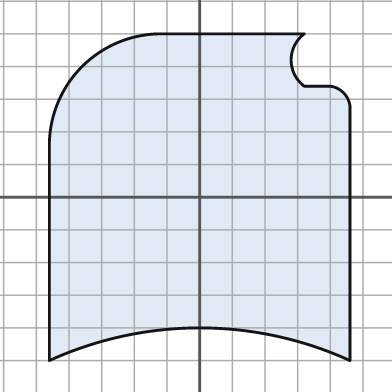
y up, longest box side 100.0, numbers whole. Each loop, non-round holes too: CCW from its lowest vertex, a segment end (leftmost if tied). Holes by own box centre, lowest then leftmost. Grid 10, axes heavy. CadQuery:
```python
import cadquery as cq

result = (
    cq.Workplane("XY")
    .moveTo(-46.0, -50.0)
    .threePointArc((0.0, -40.0), (46.0, -50.0))
    .lineTo(46.0, 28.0)
    .threePointArc((44.0, 32.0), (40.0, 34.0))
    .lineTo(32.0, 34.0)
    .threePointArc((28.0, 42.0), (32.0, 50.0))
    .lineTo(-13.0, 50.0)
    .threePointArc((-36.0, 40.0), (-46.0, 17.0))
    .close()
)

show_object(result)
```